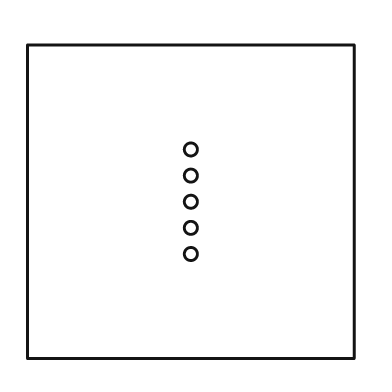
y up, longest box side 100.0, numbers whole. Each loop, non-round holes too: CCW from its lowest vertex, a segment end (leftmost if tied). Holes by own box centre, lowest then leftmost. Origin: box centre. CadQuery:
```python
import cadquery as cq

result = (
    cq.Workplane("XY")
    .moveTo(-50.0, -48.0)
    .lineTo(50.0, -48.0)
    .lineTo(50.0, 48.0)
    .lineTo(-50.0, 48.0)
    .close()
    .moveTo(0.0, -16.0)
    .circle(2.0)
    .moveTo(0.0, -8.0)
    .circle(2.0)
    .moveTo(0.0, 0.0)
    .circle(2.0)
    .moveTo(0.0, 8.0)
    .circle(2.0)
    .moveTo(0.0, 16.0)
    .circle(2.0)
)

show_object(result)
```